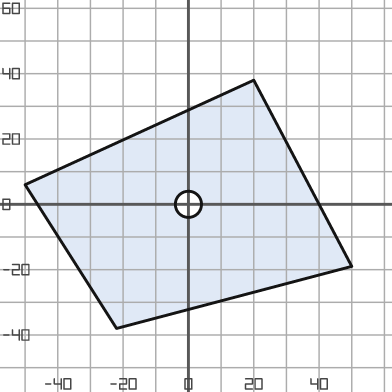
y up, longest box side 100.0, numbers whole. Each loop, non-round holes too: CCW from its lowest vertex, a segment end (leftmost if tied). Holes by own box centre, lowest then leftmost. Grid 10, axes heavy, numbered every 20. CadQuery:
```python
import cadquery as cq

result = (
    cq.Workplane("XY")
    .moveTo(-22.0, -38.0)
    .lineTo(50.0, -19.0)
    .lineTo(20.0, 38.0)
    .lineTo(-50.0, 6.0)
    .close()
    .moveTo(0.0, 0.0)
    .circle(4.0)
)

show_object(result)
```